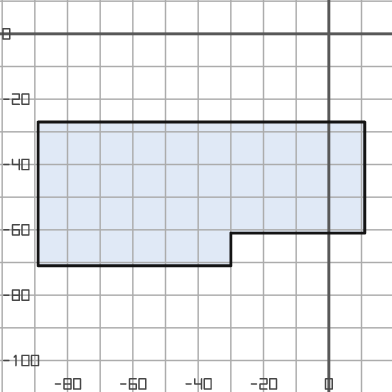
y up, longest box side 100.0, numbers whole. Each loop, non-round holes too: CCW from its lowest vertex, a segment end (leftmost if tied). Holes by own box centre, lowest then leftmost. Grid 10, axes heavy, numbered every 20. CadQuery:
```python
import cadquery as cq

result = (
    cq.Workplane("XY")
    .moveTo(-89.0, -71.0)
    .lineTo(-30.0, -71.0)
    .lineTo(-30.0, -61.0)
    .lineTo(11.0, -61.0)
    .lineTo(11.0, -27.0)
    .lineTo(-89.0, -27.0)
    .close()
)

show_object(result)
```